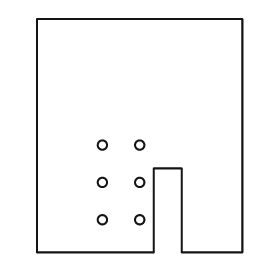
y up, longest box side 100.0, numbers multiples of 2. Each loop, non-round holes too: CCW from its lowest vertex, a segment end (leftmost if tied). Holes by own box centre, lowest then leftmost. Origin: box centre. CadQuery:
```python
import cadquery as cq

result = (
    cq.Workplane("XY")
    .moveTo(-44.0, -50.0)
    .lineTo(6.0, -50.0)
    .lineTo(6.0, -14.0)
    .lineTo(18.0, -14.0)
    .lineTo(18.0, -50.0)
    .lineTo(44.0, -50.0)
    .lineTo(44.0, 50.0)
    .lineTo(-44.0, 50.0)
    .close()
    .moveTo(-16.0, -36.0)
    .circle(2.0)
    .moveTo(0.0, -36.0)
    .circle(2.0)
    .moveTo(-16.0, -20.0)
    .circle(2.0)
    .moveTo(0.0, -20.0)
    .circle(2.0)
    .moveTo(-16.0, -4.0)
    .circle(2.0)
    .moveTo(0.0, -4.0)
    .circle(2.0)
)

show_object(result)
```